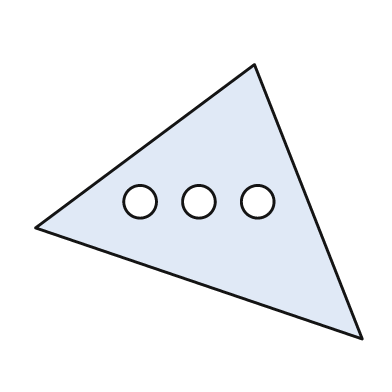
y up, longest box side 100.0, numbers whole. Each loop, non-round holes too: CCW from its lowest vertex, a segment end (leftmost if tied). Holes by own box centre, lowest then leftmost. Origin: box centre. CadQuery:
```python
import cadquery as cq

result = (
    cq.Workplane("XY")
    .moveTo(50.0, -42.0)
    .lineTo(17.0, 42.0)
    .lineTo(-50.0, -8.0)
    .close()
    .moveTo(-18.0, 0.0)
    .circle(5.0)
    .moveTo(0.0, 0.0)
    .circle(5.0)
    .moveTo(18.0, 0.0)
    .circle(5.0)
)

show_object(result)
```